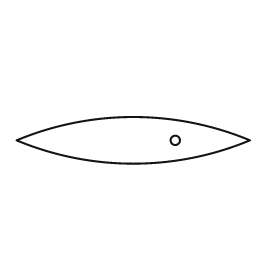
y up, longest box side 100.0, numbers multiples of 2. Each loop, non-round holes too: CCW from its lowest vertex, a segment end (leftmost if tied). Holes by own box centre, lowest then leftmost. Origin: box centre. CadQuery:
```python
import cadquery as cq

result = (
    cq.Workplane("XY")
    .moveTo(-50.0, 0.0)
    .threePointArc((0.0, -10.0), (50.0, 0.0))
    .threePointArc((0.0, 10.0), (-50.0, 0.0))
    .close()
    .moveTo(18.0, 0.0)
    .circle(2.0)
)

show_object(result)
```